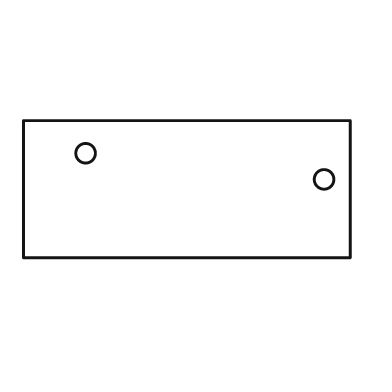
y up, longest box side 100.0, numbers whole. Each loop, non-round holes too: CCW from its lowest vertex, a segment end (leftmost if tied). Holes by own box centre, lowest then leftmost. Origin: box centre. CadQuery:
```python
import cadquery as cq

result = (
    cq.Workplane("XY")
    .moveTo(-50.0, -21.0)
    .lineTo(50.0, -21.0)
    .lineTo(50.0, 21.0)
    .lineTo(-50.0, 21.0)
    .close()
    .moveTo(42.0, 3.0)
    .circle(3.0)
    .moveTo(-31.0, 11.0)
    .circle(3.0)
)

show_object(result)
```